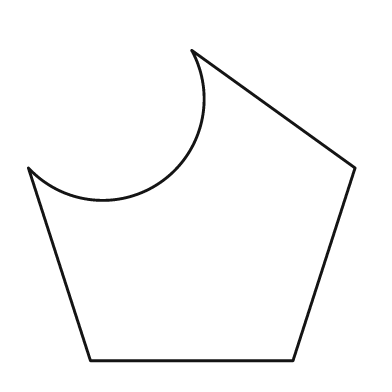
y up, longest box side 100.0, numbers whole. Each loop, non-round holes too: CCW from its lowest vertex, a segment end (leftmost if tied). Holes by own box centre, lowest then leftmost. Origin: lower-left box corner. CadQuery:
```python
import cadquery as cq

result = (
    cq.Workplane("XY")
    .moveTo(19.0, 0.0)
    .lineTo(81.0, 0.0)
    .lineTo(100.0, 59.0)
    .lineTo(50.0, 95.0)
    .threePointArc((41.0, 55.0), (0.0, 59.0))
    .close()
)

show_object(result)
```